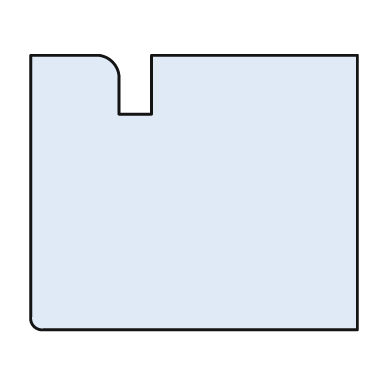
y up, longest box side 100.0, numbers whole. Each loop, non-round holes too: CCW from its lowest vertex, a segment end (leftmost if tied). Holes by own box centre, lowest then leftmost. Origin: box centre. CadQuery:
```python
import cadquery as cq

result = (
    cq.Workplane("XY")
    .moveTo(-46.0, -42.0)
    .lineTo(50.0, -42.0)
    .lineTo(50.0, 42.0)
    .lineTo(-13.0, 42.0)
    .lineTo(-13.0, 24.0)
    .lineTo(-23.0, 24.0)
    .lineTo(-23.0, 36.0)
    .threePointArc((-25.0, 40.0), (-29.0, 42.0))
    .lineTo(-50.0, 42.0)
    .lineTo(-50.0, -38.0)
    .threePointArc((-49.0, -41.0), (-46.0, -42.0))
    .close()
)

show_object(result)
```